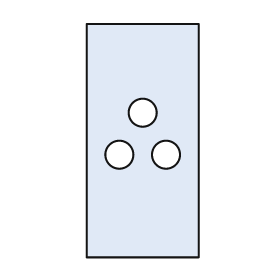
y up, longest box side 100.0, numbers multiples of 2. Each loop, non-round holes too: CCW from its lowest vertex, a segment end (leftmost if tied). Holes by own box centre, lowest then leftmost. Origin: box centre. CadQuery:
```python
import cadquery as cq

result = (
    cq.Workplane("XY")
    .moveTo(-24.0, -50.0)
    .lineTo(24.0, -50.0)
    .lineTo(24.0, 50.0)
    .lineTo(-24.0, 50.0)
    .close()
    .moveTo(-10.0, -6.0)
    .circle(6.0)
    .moveTo(10.0, -6.0)
    .circle(6.0)
    .moveTo(0.0, 12.0)
    .circle(6.0)
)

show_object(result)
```